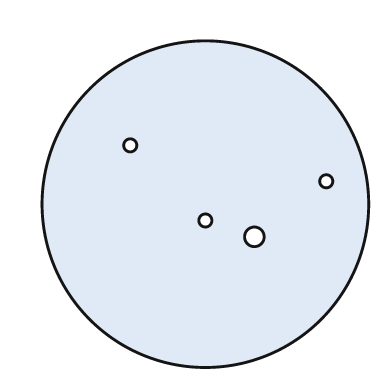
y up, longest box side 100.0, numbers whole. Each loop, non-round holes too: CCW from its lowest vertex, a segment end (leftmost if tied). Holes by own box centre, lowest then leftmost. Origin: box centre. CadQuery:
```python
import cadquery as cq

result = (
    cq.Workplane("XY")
    .moveTo(0.0, 0.0)
    .circle(50.0)
    .moveTo(15.0, -10.0)
    .circle(3.0)
    .moveTo(0.0, -5.0)
    .circle(2.0)
    .moveTo(37.0, 7.0)
    .circle(2.0)
    .moveTo(-23.0, 18.0)
    .circle(2.0)
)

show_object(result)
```